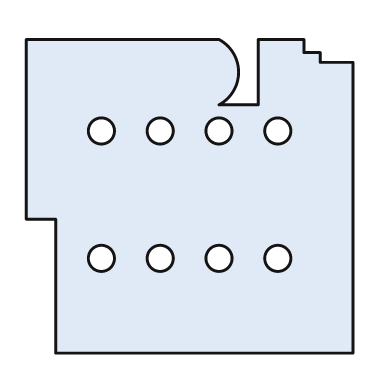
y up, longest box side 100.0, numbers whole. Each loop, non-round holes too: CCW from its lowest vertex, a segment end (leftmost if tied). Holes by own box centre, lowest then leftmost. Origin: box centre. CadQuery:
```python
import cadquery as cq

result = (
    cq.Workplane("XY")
    .moveTo(-41.0, -48.0)
    .lineTo(50.0, -48.0)
    .lineTo(50.0, 41.0)
    .lineTo(40.0, 41.0)
    .lineTo(40.0, 44.0)
    .lineTo(35.0, 44.0)
    .lineTo(35.0, 48.0)
    .lineTo(21.0, 48.0)
    .lineTo(21.0, 28.0)
    .lineTo(9.0, 28.0)
    .threePointArc((15.0, 38.0), (9.0, 48.0))
    .lineTo(-50.0, 48.0)
    .lineTo(-50.0, -7.0)
    .lineTo(-41.0, -7.0)
    .close()
    .moveTo(-27.0, -19.0)
    .circle(4.0)
    .moveTo(-9.0, -19.0)
    .circle(4.0)
    .moveTo(9.0, -19.0)
    .circle(4.0)
    .moveTo(27.0, -19.0)
    .circle(4.0)
    .moveTo(-27.0, 20.0)
    .circle(4.0)
    .moveTo(-9.0, 20.0)
    .circle(4.0)
    .moveTo(9.0, 20.0)
    .circle(4.0)
    .moveTo(27.0, 20.0)
    .circle(4.0)
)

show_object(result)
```